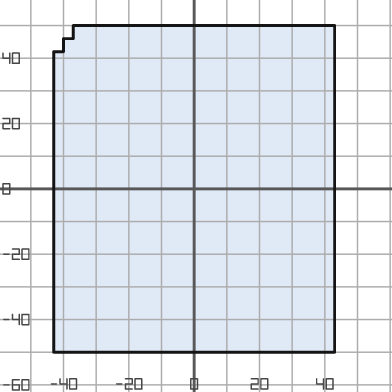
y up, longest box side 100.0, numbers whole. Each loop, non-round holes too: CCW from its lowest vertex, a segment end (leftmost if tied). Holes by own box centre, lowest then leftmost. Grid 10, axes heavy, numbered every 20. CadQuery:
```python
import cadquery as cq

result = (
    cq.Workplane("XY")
    .moveTo(-43.0, -50.0)
    .lineTo(43.0, -50.0)
    .lineTo(43.0, 50.0)
    .lineTo(-37.0, 50.0)
    .lineTo(-37.0, 46.0)
    .lineTo(-40.0, 46.0)
    .lineTo(-40.0, 42.0)
    .lineTo(-43.0, 42.0)
    .close()
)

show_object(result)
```